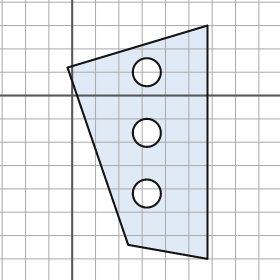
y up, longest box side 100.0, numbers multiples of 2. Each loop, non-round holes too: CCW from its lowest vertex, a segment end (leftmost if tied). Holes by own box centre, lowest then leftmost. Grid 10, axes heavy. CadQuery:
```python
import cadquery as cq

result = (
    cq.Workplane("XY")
    .moveTo(58.0, -70.0)
    .lineTo(58.0, 30.0)
    .lineTo(-2.0, 12.0)
    .lineTo(24.0, -64.0)
    .close()
    .moveTo(32.0, -42.0)
    .circle(6.0)
    .moveTo(32.0, -16.0)
    .circle(6.0)
    .moveTo(32.0, 10.0)
    .circle(6.0)
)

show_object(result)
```